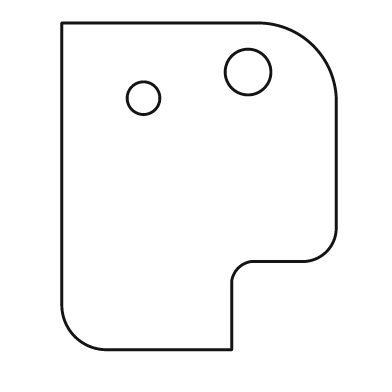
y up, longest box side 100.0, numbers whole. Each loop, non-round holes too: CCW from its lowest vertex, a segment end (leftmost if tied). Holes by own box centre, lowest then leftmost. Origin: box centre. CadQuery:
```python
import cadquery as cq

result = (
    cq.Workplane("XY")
    .moveTo(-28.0, -50.0)
    .lineTo(10.0, -50.0)
    .lineTo(10.0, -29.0)
    .threePointArc((12.0, -25.0), (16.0, -23.0))
    .lineTo(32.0, -23.0)
    .threePointArc((39.0, -20.0), (42.0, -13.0))
    .lineTo(42.0, 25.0)
    .threePointArc((35.0, 43.0), (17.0, 50.0))
    .lineTo(-42.0, 50.0)
    .lineTo(-42.0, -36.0)
    .threePointArc((-38.0, -46.0), (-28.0, -50.0))
    .close()
    .moveTo(-17.0, 27.0)
    .circle(5.0)
    .moveTo(15.0, 35.0)
    .circle(7.0)
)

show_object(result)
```